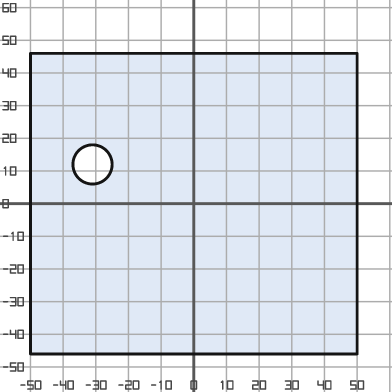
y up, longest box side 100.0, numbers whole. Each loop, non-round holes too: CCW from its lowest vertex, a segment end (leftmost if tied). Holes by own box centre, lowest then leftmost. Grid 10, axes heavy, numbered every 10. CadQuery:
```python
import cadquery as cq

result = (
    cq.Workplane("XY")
    .moveTo(-50.0, -46.0)
    .lineTo(50.0, -46.0)
    .lineTo(50.0, 46.0)
    .lineTo(-50.0, 46.0)
    .close()
    .moveTo(-31.0, 12.0)
    .circle(6.0)
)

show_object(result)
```